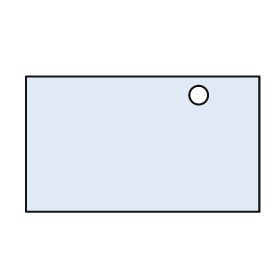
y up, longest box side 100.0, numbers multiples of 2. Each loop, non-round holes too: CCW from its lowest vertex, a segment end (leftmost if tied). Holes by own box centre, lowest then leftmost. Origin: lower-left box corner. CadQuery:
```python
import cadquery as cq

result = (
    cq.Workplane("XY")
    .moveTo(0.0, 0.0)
    .lineTo(100.0, 0.0)
    .lineTo(100.0, 58.0)
    .lineTo(0.0, 58.0)
    .close()
    .moveTo(74.0, 50.0)
    .circle(4.0)
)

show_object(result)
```